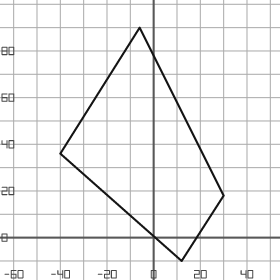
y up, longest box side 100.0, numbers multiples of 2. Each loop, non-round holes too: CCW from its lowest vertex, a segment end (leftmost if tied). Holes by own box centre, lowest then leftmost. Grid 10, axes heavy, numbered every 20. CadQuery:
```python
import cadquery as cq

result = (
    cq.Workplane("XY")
    .moveTo(12.0, -10.0)
    .lineTo(30.0, 18.0)
    .lineTo(-6.0, 90.0)
    .lineTo(-40.0, 36.0)
    .close()
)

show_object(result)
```